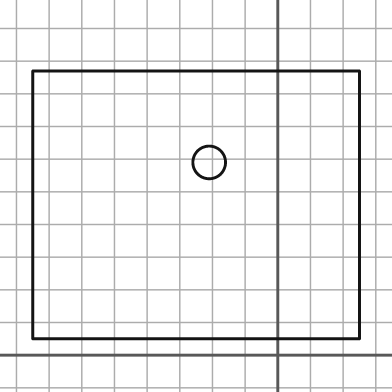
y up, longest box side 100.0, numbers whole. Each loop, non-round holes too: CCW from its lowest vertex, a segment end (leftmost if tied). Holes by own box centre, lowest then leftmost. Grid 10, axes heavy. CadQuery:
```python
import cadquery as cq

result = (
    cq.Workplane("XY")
    .moveTo(-75.0, 5.0)
    .lineTo(25.0, 5.0)
    .lineTo(25.0, 87.0)
    .lineTo(-75.0, 87.0)
    .close()
    .moveTo(-21.0, 59.0)
    .circle(5.0)
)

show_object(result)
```